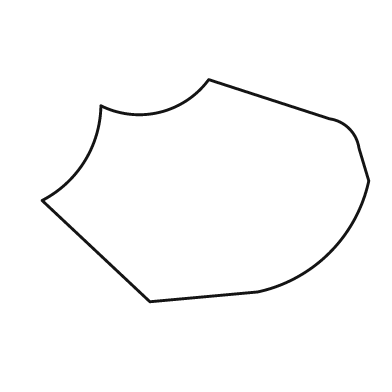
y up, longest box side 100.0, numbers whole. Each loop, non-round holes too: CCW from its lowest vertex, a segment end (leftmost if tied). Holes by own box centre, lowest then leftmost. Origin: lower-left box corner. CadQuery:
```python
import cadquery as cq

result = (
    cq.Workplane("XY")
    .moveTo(33.0, 0.0)
    .lineTo(66.0, 3.0)
    .threePointArc((88.0, 15.0), (100.0, 37.0))
    .lineTo(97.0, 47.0)
    .threePointArc((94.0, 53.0), (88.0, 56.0))
    .lineTo(51.0, 68.0)
    .threePointArc((36.0, 58.0), (18.0, 60.0))
    .threePointArc((13.0, 43.0), (0.0, 31.0))
    .close()
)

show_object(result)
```